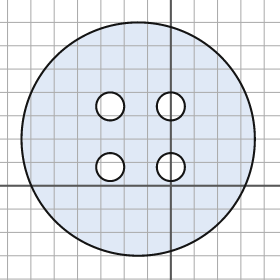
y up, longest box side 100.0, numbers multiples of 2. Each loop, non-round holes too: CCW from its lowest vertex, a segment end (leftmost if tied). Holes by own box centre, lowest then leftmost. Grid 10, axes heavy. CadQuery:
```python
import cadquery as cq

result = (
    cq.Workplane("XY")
    .moveTo(-14.0, 20.0)
    .circle(50.0)
    .moveTo(-26.0, 8.0)
    .circle(6.0)
    .moveTo(0.0, 8.0)
    .circle(6.0)
    .moveTo(-26.0, 34.0)
    .circle(6.0)
    .moveTo(0.0, 34.0)
    .circle(6.0)
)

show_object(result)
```